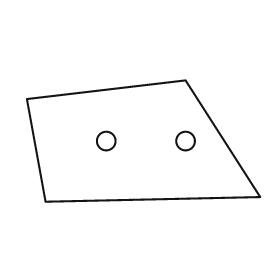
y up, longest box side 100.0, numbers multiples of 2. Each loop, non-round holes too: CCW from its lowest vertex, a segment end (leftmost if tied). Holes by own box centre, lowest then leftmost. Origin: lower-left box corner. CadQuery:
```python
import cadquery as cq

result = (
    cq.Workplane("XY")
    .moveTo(8.0, 0.0)
    .lineTo(100.0, 2.0)
    .lineTo(68.0, 52.0)
    .lineTo(0.0, 44.0)
    .close()
    .moveTo(34.0, 26.0)
    .circle(4.0)
    .moveTo(68.0, 26.0)
    .circle(4.0)
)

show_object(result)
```